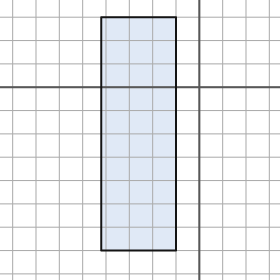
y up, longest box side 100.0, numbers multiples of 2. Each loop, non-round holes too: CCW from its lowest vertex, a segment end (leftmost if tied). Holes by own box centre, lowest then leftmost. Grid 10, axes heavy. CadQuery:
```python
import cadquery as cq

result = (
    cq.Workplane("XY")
    .moveTo(-42.0, -70.0)
    .lineTo(-10.0, -70.0)
    .lineTo(-10.0, 30.0)
    .lineTo(-42.0, 30.0)
    .close()
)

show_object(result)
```